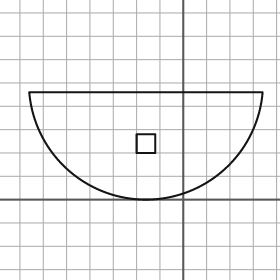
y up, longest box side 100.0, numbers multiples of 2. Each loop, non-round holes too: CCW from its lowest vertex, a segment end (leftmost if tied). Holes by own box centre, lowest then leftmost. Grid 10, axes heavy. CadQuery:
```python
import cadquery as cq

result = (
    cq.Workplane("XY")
    .moveTo(-66.0, 46.0)
    .threePointArc((-16.0, 0.0), (34.0, 46.0))
    .close()
    .moveTo(-20.0, 20.0)
    .lineTo(-12.0, 20.0)
    .lineTo(-12.0, 28.0)
    .lineTo(-20.0, 28.0)
    .close()
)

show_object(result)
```